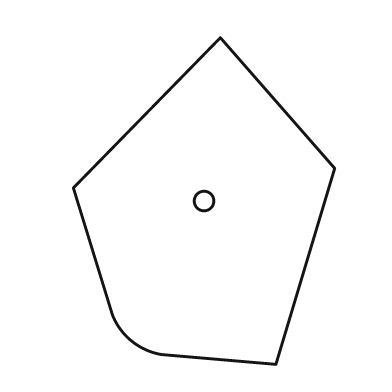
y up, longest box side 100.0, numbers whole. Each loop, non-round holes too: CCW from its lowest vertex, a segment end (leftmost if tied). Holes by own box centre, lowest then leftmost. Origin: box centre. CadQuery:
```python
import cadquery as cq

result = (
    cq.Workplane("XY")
    .moveTo(22.0, -50.0)
    .lineTo(40.0, 10.0)
    .lineTo(5.0, 50.0)
    .lineTo(-40.0, 4.0)
    .lineTo(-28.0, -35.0)
    .threePointArc((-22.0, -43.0), (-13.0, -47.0))
    .close()
    .moveTo(0.0, 0.0)
    .circle(3.0)
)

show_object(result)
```